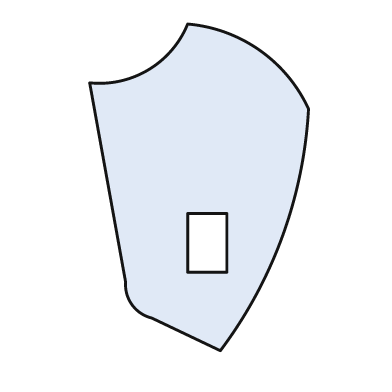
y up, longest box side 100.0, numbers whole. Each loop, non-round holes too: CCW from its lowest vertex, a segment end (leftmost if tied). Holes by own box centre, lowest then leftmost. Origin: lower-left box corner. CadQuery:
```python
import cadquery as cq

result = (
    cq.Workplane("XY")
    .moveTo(40.0, 0.0)
    .threePointArc((59.0, 35.0), (67.0, 74.0))
    .threePointArc((52.0, 92.0), (30.0, 100.0))
    .threePointArc((18.0, 86.0), (0.0, 82.0))
    .lineTo(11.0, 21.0)
    .threePointArc((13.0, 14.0), (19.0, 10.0))
    .close()
    .moveTo(30.0, 24.0)
    .lineTo(42.0, 24.0)
    .lineTo(42.0, 42.0)
    .lineTo(30.0, 42.0)
    .close()
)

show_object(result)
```